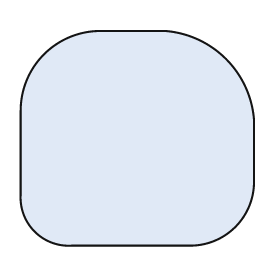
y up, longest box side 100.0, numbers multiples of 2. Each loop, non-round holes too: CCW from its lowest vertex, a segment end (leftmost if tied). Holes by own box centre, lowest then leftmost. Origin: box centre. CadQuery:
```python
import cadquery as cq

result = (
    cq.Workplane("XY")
    .moveTo(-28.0, -46.0)
    .lineTo(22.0, -46.0)
    .threePointArc((42.0, -38.0), (50.0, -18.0))
    .lineTo(50.0, 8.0)
    .threePointArc((38.0, 34.0), (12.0, 46.0))
    .lineTo(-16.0, 46.0)
    .threePointArc((-40.0, 36.0), (-50.0, 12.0))
    .lineTo(-50.0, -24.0)
    .threePointArc((-44.0, -40.0), (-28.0, -46.0))
    .close()
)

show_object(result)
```